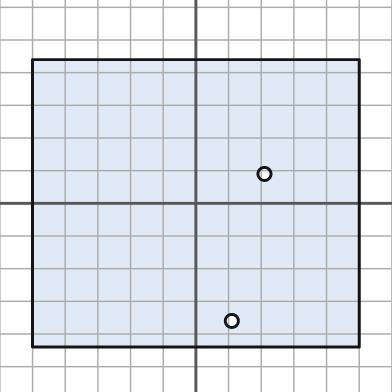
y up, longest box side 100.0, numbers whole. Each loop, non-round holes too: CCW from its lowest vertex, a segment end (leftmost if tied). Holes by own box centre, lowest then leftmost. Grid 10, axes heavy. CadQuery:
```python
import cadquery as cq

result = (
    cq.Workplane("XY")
    .moveTo(-50.0, -44.0)
    .lineTo(50.0, -44.0)
    .lineTo(50.0, 44.0)
    .lineTo(-50.0, 44.0)
    .close()
    .moveTo(11.0, -36.0)
    .circle(2.0)
    .moveTo(21.0, 9.0)
    .circle(2.0)
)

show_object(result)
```